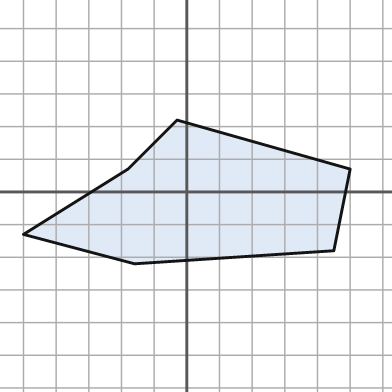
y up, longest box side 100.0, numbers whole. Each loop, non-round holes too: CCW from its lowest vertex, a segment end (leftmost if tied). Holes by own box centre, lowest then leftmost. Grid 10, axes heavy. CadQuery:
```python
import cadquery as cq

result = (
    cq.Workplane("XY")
    .moveTo(-16.0, -22.0)
    .lineTo(45.0, -18.0)
    .lineTo(50.0, 7.0)
    .lineTo(-3.0, 22.0)
    .lineTo(-18.0, 7.0)
    .lineTo(-50.0, -13.0)
    .close()
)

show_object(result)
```